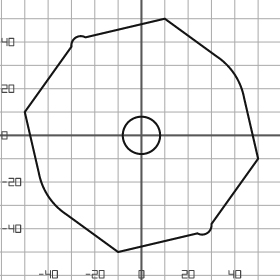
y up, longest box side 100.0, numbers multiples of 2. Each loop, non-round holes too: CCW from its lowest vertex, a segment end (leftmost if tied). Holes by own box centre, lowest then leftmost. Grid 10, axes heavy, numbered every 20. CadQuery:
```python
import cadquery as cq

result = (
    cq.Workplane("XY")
    .moveTo(-10.0, -50.0)
    .lineTo(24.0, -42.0)
    .threePointArc((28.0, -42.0), (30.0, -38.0))
    .lineTo(50.0, -10.0)
    .lineTo(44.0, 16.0)
    .threePointArc((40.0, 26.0), (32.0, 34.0))
    .lineTo(10.0, 50.0)
    .lineTo(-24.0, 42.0)
    .threePointArc((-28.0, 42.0), (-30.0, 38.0))
    .lineTo(-50.0, 10.0)
    .lineTo(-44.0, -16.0)
    .threePointArc((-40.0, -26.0), (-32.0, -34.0))
    .close()
    .moveTo(0.0, 0.0)
    .circle(8.0)
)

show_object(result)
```